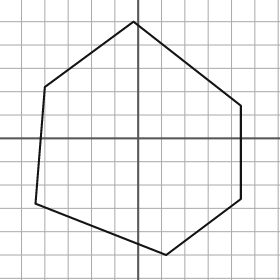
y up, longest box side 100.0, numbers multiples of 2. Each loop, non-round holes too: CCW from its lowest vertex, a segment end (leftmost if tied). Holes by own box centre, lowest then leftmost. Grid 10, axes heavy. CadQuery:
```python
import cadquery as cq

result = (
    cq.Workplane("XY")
    .moveTo(12.0, -50.0)
    .lineTo(44.0, -26.0)
    .lineTo(44.0, 14.0)
    .lineTo(-2.0, 50.0)
    .lineTo(-40.0, 22.0)
    .lineTo(-44.0, -28.0)
    .close()
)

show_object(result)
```